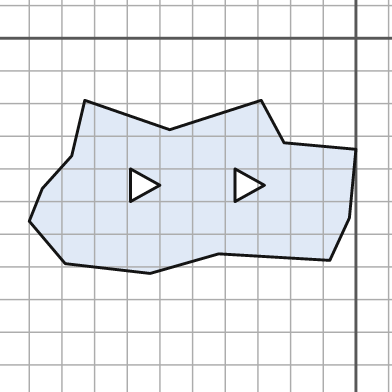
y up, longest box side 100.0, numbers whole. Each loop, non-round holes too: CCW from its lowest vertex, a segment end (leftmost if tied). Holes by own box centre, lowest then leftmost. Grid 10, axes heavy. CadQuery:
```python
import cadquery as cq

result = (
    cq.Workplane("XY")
    .moveTo(-63.0, -72.0)
    .lineTo(-42.0, -66.0)
    .lineTo(-8.0, -68.0)
    .lineTo(-2.0, -55.0)
    .lineTo(0.0, -34.0)
    .lineTo(-22.0, -32.0)
    .lineTo(-29.0, -19.0)
    .lineTo(-57.0, -28.0)
    .lineTo(-83.0, -19.0)
    .lineTo(-87.0, -36.0)
    .lineTo(-96.0, -46.0)
    .lineTo(-100.0, -56.0)
    .lineTo(-89.0, -69.0)
    .close()
    .moveTo(-69.0, -50.0)
    .lineTo(-60.0, -45.0)
    .lineTo(-69.0, -40.0)
    .close()
    .moveTo(-37.0, -50.0)
    .lineTo(-28.0, -45.0)
    .lineTo(-37.0, -40.0)
    .close()
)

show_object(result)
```